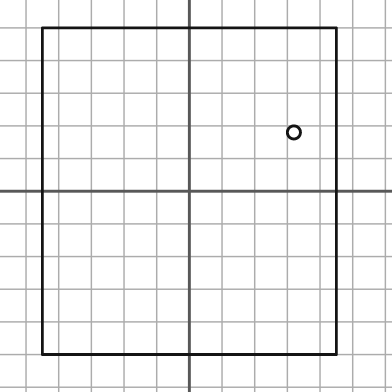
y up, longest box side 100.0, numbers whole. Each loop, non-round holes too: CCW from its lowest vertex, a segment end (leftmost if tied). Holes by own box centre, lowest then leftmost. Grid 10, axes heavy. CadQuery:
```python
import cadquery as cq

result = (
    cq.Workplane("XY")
    .moveTo(-45.0, -50.0)
    .lineTo(45.0, -50.0)
    .lineTo(45.0, 50.0)
    .lineTo(-45.0, 50.0)
    .close()
    .moveTo(32.0, 18.0)
    .circle(2.0)
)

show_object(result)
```